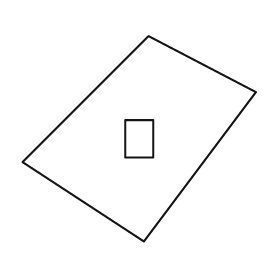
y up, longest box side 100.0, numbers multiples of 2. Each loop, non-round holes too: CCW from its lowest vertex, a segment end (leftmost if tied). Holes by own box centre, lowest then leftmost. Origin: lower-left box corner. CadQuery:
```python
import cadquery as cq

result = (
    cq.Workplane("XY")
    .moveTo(52.0, 0.0)
    .lineTo(100.0, 64.0)
    .lineTo(54.0, 88.0)
    .lineTo(0.0, 34.0)
    .close()
    .moveTo(44.0, 36.0)
    .lineTo(56.0, 36.0)
    .lineTo(56.0, 52.0)
    .lineTo(44.0, 52.0)
    .close()
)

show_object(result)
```